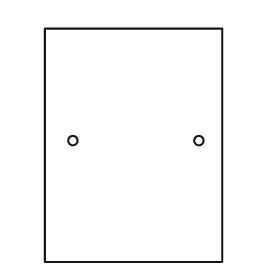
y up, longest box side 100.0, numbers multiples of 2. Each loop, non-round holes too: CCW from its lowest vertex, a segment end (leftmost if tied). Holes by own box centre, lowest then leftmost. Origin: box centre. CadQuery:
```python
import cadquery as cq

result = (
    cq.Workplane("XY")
    .moveTo(-38.0, -50.0)
    .lineTo(38.0, -50.0)
    .lineTo(38.0, 50.0)
    .lineTo(-38.0, 50.0)
    .close()
    .moveTo(-26.0, 2.0)
    .circle(2.0)
    .moveTo(28.0, 2.0)
    .circle(2.0)
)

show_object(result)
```